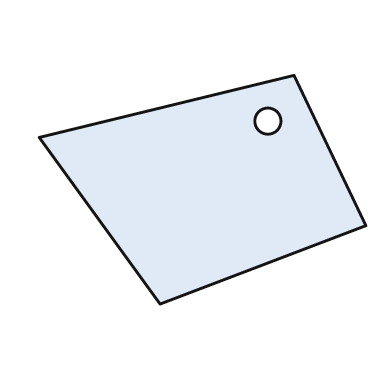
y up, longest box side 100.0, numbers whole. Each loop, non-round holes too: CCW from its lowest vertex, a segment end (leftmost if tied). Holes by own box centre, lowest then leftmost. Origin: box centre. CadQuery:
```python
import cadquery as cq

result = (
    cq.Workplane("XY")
    .moveTo(-13.0, -35.0)
    .lineTo(50.0, -11.0)
    .lineTo(28.0, 35.0)
    .lineTo(-50.0, 16.0)
    .close()
    .moveTo(20.0, 21.0)
    .circle(4.0)
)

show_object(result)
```